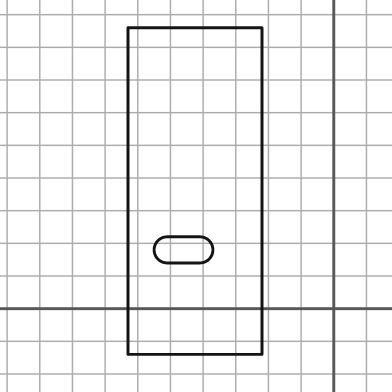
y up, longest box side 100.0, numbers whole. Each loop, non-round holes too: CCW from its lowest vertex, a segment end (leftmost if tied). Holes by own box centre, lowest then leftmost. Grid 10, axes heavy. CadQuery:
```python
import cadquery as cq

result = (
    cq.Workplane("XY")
    .moveTo(-63.0, -14.0)
    .lineTo(-22.0, -14.0)
    .lineTo(-22.0, 86.0)
    .lineTo(-63.0, 86.0)
    .close()
    .moveTo(-51.0, 14.0)
    .lineTo(-41.0, 14.0)
    .threePointArc((-37.0, 18.0), (-41.0, 22.0))
    .lineTo(-51.0, 22.0)
    .threePointArc((-55.0, 18.0), (-51.0, 14.0))
    .close()
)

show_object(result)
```